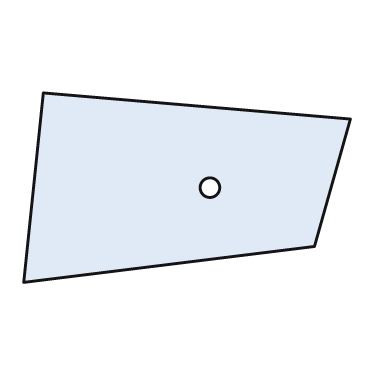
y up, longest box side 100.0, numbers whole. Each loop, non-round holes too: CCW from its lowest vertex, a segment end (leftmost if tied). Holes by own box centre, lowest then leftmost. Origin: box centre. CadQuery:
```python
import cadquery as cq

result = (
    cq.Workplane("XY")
    .moveTo(-50.0, -29.0)
    .lineTo(39.0, -18.0)
    .lineTo(50.0, 21.0)
    .lineTo(-44.0, 29.0)
    .close()
    .moveTo(7.0, 0.0)
    .circle(3.0)
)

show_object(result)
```